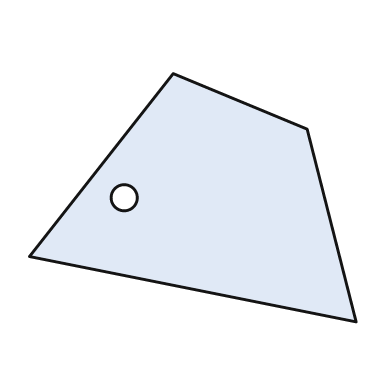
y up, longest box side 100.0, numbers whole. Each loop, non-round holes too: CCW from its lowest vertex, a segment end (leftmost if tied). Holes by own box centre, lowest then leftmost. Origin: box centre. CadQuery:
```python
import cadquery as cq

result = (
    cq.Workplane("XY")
    .moveTo(50.0, -38.0)
    .lineTo(35.0, 21.0)
    .lineTo(-6.0, 38.0)
    .lineTo(-50.0, -18.0)
    .close()
    .moveTo(-21.0, 0.0)
    .circle(4.0)
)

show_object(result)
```